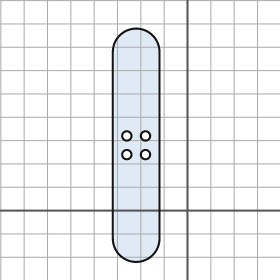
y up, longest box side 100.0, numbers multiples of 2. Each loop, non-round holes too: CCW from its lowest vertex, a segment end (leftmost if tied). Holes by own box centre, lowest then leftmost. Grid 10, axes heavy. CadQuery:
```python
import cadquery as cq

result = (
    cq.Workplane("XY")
    .moveTo(-32.0, -12.0)
    .threePointArc((-22.0, -22.0), (-12.0, -12.0))
    .lineTo(-12.0, 68.0)
    .threePointArc((-22.0, 78.0), (-32.0, 68.0))
    .close()
    .moveTo(-26.0, 24.0)
    .circle(2.0)
    .moveTo(-18.0, 24.0)
    .circle(2.0)
    .moveTo(-26.0, 32.0)
    .circle(2.0)
    .moveTo(-18.0, 32.0)
    .circle(2.0)
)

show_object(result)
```